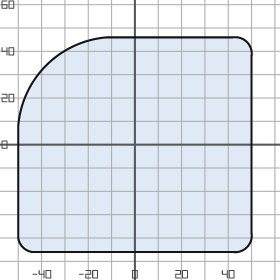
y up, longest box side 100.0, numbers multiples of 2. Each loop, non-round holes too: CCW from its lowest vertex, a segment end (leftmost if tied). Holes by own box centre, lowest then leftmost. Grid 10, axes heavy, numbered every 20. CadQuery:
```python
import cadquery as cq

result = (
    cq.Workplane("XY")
    .moveTo(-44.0, -46.0)
    .lineTo(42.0, -46.0)
    .threePointArc((48.0, -44.0), (50.0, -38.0))
    .lineTo(50.0, 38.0)
    .threePointArc((48.0, 44.0), (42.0, 46.0))
    .lineTo(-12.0, 46.0)
    .threePointArc((-38.0, 34.0), (-50.0, 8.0))
    .lineTo(-50.0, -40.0)
    .threePointArc((-48.0, -44.0), (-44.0, -46.0))
    .close()
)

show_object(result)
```